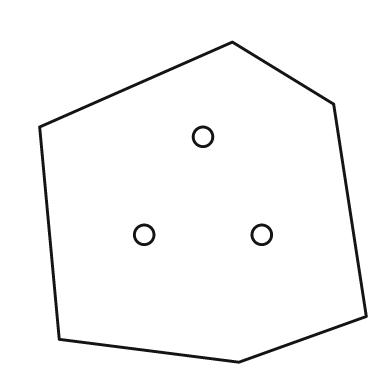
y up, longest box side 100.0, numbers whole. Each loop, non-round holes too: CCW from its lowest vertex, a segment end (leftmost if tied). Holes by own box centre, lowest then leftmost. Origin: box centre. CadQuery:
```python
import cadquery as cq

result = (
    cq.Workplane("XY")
    .moveTo(11.0, -49.0)
    .lineTo(50.0, -35.0)
    .lineTo(40.0, 30.0)
    .lineTo(9.0, 49.0)
    .lineTo(-50.0, 23.0)
    .lineTo(-44.0, -42.0)
    .close()
    .moveTo(-18.0, -10.0)
    .circle(3.0)
    .moveTo(18.0, -10.0)
    .circle(3.0)
    .moveTo(0.0, 20.0)
    .circle(3.0)
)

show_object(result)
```